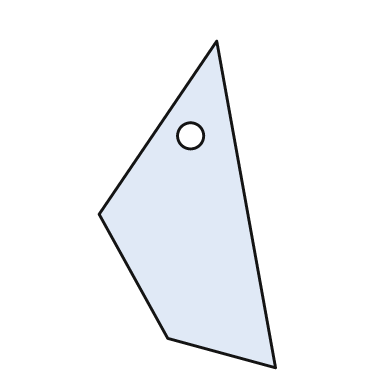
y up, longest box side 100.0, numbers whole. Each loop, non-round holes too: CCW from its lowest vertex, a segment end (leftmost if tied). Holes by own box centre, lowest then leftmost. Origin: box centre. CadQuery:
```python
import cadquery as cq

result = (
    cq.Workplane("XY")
    .moveTo(27.0, -50.0)
    .lineTo(9.0, 50.0)
    .lineTo(-27.0, -3.0)
    .lineTo(-6.0, -41.0)
    .close()
    .moveTo(1.0, 21.0)
    .circle(4.0)
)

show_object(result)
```